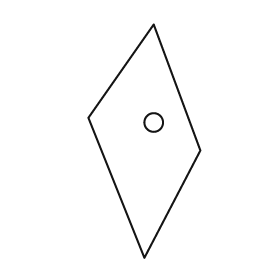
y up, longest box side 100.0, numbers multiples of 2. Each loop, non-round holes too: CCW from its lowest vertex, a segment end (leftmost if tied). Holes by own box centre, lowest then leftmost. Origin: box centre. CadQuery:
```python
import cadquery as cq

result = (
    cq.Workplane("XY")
    .moveTo(0.0, -50.0)
    .lineTo(24.0, -4.0)
    .lineTo(4.0, 50.0)
    .lineTo(-24.0, 10.0)
    .close()
    .moveTo(4.0, 8.0)
    .circle(4.0)
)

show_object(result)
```